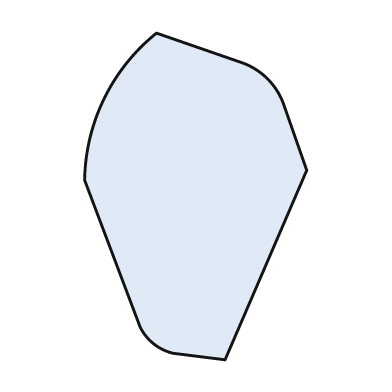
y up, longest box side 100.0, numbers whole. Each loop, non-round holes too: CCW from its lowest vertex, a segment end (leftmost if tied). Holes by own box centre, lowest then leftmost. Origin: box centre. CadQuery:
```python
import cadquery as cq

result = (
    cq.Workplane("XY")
    .moveTo(9.0, -50.0)
    .lineTo(34.0, 8.0)
    .lineTo(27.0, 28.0)
    .threePointArc((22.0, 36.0), (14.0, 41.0))
    .lineTo(-12.0, 50.0)
    .threePointArc((-28.0, 30.0), (-34.0, 5.0))
    .lineTo(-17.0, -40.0)
    .threePointArc((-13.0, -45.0), (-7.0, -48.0))
    .close()
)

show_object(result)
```